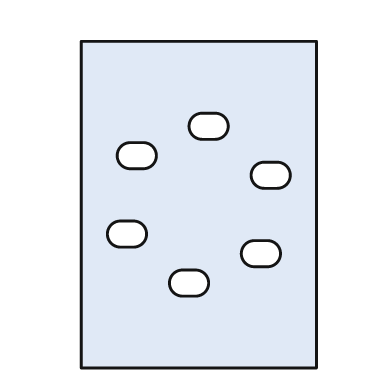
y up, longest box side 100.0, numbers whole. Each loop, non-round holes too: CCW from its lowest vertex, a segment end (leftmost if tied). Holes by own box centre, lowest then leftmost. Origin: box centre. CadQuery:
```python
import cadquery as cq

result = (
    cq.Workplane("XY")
    .moveTo(-36.0, -50.0)
    .lineTo(36.0, -50.0)
    .lineTo(36.0, 50.0)
    .lineTo(-36.0, 50.0)
    .close()
    .moveTo(-5.0, -28.0)
    .lineTo(-1.0, -28.0)
    .threePointArc((3.0, -24.0), (-1.0, -20.0))
    .lineTo(-5.0, -20.0)
    .threePointArc((-9.0, -24.0), (-5.0, -28.0))
    .close()
    .moveTo(17.0, -19.0)
    .lineTo(21.0, -19.0)
    .threePointArc((25.0, -15.0), (21.0, -11.0))
    .lineTo(17.0, -11.0)
    .threePointArc((13.0, -15.0), (17.0, -19.0))
    .close()
    .moveTo(-24.0, -13.0)
    .lineTo(-20.0, -13.0)
    .threePointArc((-16.0, -9.0), (-20.0, -5.0))
    .lineTo(-24.0, -5.0)
    .threePointArc((-28.0, -9.0), (-24.0, -13.0))
    .close()
    .moveTo(20.0, 5.0)
    .lineTo(24.0, 5.0)
    .threePointArc((28.0, 9.0), (24.0, 13.0))
    .lineTo(20.0, 13.0)
    .threePointArc((16.0, 9.0), (20.0, 5.0))
    .close()
    .moveTo(-21.0, 11.0)
    .lineTo(-17.0, 11.0)
    .threePointArc((-13.0, 15.0), (-17.0, 19.0))
    .lineTo(-21.0, 19.0)
    .threePointArc((-25.0, 15.0), (-21.0, 11.0))
    .close()
    .moveTo(1.0, 20.0)
    .lineTo(5.0, 20.0)
    .threePointArc((9.0, 24.0), (5.0, 28.0))
    .lineTo(1.0, 28.0)
    .threePointArc((-3.0, 24.0), (1.0, 20.0))
    .close()
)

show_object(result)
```